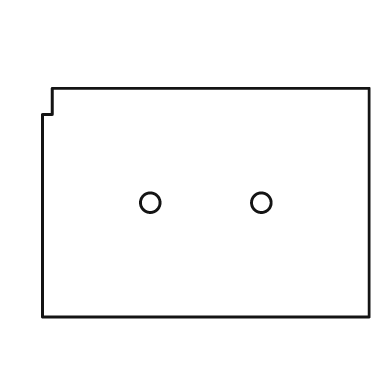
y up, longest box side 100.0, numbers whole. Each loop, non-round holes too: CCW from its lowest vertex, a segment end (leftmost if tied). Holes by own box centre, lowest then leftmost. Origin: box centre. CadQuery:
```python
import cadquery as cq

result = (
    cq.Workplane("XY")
    .moveTo(-50.0, -35.0)
    .lineTo(50.0, -35.0)
    .lineTo(50.0, 35.0)
    .lineTo(-47.0, 35.0)
    .lineTo(-47.0, 27.0)
    .lineTo(-50.0, 27.0)
    .close()
    .moveTo(-17.0, 0.0)
    .circle(3.0)
    .moveTo(17.0, 0.0)
    .circle(3.0)
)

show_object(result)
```